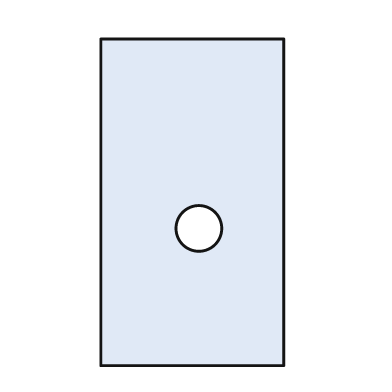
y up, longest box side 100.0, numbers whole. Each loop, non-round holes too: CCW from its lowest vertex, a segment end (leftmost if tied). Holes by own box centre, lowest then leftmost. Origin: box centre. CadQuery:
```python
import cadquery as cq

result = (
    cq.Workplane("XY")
    .moveTo(-28.0, -50.0)
    .lineTo(28.0, -50.0)
    .lineTo(28.0, 50.0)
    .lineTo(-28.0, 50.0)
    .close()
    .moveTo(2.0, -8.0)
    .circle(7.0)
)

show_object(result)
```